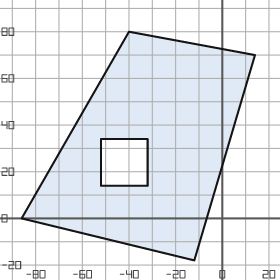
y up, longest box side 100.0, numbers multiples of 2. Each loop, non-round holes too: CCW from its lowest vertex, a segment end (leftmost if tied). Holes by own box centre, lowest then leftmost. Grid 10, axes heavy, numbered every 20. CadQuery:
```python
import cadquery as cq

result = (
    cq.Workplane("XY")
    .moveTo(-12.0, -18.0)
    .lineTo(14.0, 70.0)
    .lineTo(-40.0, 80.0)
    .lineTo(-86.0, 0.0)
    .close()
    .moveTo(-52.0, 14.0)
    .lineTo(-32.0, 14.0)
    .lineTo(-32.0, 34.0)
    .lineTo(-52.0, 34.0)
    .close()
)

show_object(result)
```